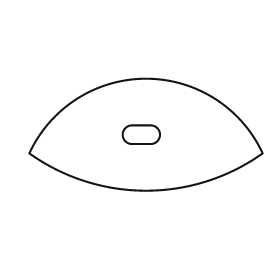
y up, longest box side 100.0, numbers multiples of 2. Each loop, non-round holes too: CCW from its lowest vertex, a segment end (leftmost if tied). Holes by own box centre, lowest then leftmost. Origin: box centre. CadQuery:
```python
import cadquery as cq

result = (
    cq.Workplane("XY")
    .moveTo(-50.0, -8.0)
    .threePointArc((0.0, -24.0), (50.0, -8.0))
    .threePointArc((0.0, 24.0), (-50.0, -8.0))
    .close()
    .moveTo(-6.0, -4.0)
    .lineTo(2.0, -4.0)
    .threePointArc((6.0, 0.0), (2.0, 4.0))
    .lineTo(-6.0, 4.0)
    .threePointArc((-10.0, 0.0), (-6.0, -4.0))
    .close()
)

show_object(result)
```